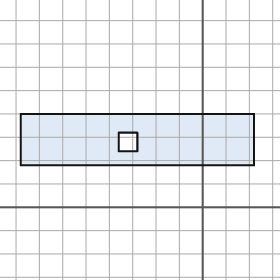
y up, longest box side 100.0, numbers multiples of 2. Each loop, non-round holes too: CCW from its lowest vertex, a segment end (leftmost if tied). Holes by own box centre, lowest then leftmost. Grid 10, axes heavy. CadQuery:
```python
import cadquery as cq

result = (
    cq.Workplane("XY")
    .moveTo(-78.0, 18.0)
    .lineTo(22.0, 18.0)
    .lineTo(22.0, 40.0)
    .lineTo(-78.0, 40.0)
    .close()
    .moveTo(-36.0, 24.0)
    .lineTo(-28.0, 24.0)
    .lineTo(-28.0, 32.0)
    .lineTo(-36.0, 32.0)
    .close()
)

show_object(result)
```